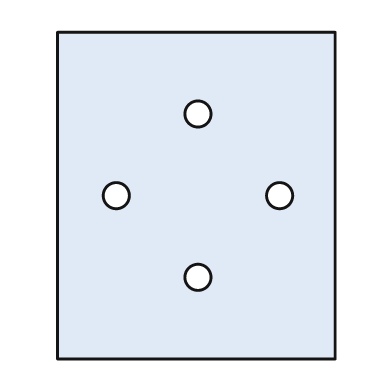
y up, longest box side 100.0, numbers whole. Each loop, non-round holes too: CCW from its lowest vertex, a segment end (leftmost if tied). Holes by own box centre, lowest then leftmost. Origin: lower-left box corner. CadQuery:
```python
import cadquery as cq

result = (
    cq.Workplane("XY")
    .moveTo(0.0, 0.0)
    .lineTo(85.0, 0.0)
    .lineTo(85.0, 100.0)
    .lineTo(0.0, 100.0)
    .close()
    .moveTo(43.0, 25.0)
    .circle(4.0)
    .moveTo(18.0, 50.0)
    .circle(4.0)
    .moveTo(68.0, 50.0)
    .circle(4.0)
    .moveTo(43.0, 75.0)
    .circle(4.0)
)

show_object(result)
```